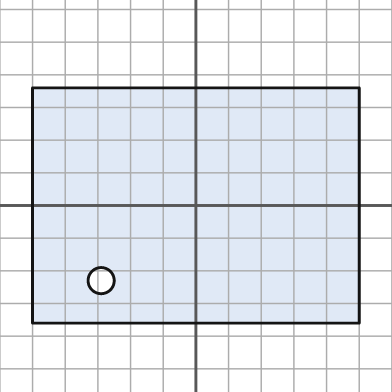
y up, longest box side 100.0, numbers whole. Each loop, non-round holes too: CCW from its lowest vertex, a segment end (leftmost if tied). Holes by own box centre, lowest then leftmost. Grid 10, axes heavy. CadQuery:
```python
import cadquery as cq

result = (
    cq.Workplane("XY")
    .moveTo(-50.0, -36.0)
    .lineTo(50.0, -36.0)
    .lineTo(50.0, 36.0)
    .lineTo(-50.0, 36.0)
    .close()
    .moveTo(-29.0, -23.0)
    .circle(4.0)
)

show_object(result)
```